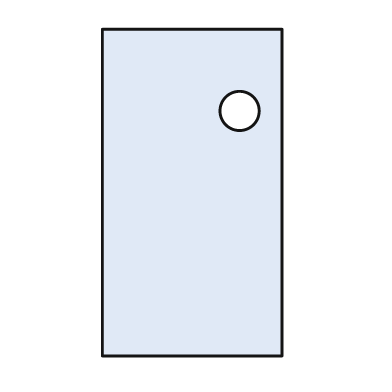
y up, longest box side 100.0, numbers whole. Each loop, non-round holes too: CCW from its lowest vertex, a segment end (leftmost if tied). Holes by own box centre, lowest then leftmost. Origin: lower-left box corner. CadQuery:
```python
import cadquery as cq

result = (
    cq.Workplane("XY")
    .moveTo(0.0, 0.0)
    .lineTo(55.0, 0.0)
    .lineTo(55.0, 100.0)
    .lineTo(0.0, 100.0)
    .close()
    .moveTo(42.0, 75.0)
    .circle(6.0)
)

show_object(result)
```